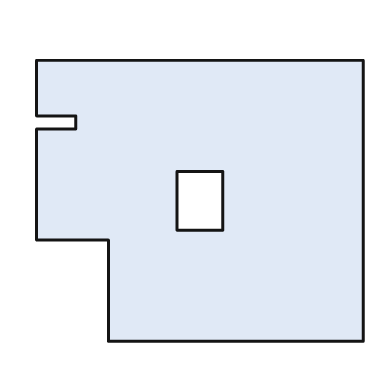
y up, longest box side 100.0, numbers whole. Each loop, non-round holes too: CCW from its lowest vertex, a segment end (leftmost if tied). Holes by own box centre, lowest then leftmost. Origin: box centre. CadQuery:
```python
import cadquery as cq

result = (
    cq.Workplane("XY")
    .moveTo(-28.0, -43.0)
    .lineTo(50.0, -43.0)
    .lineTo(50.0, 43.0)
    .lineTo(-50.0, 43.0)
    .lineTo(-50.0, 26.0)
    .lineTo(-38.0, 26.0)
    .lineTo(-38.0, 22.0)
    .lineTo(-50.0, 22.0)
    .lineTo(-50.0, -12.0)
    .lineTo(-28.0, -12.0)
    .close()
    .moveTo(-7.0, -9.0)
    .lineTo(7.0, -9.0)
    .lineTo(7.0, 9.0)
    .lineTo(-7.0, 9.0)
    .close()
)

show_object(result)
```